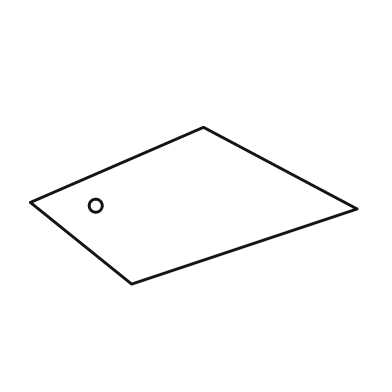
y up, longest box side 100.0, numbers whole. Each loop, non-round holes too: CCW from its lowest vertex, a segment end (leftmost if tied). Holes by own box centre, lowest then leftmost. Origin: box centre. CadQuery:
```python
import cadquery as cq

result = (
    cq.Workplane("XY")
    .moveTo(-19.0, -24.0)
    .lineTo(50.0, -1.0)
    .lineTo(3.0, 24.0)
    .lineTo(-50.0, 1.0)
    .close()
    .moveTo(-30.0, 0.0)
    .circle(2.0)
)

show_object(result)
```